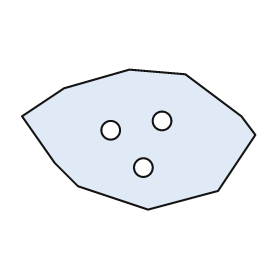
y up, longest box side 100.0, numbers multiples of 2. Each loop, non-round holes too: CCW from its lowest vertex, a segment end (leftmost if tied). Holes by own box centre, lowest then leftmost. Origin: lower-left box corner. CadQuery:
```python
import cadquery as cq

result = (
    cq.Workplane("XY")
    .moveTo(54.0, 0.0)
    .lineTo(84.0, 8.0)
    .lineTo(100.0, 32.0)
    .lineTo(94.0, 40.0)
    .lineTo(70.0, 58.0)
    .lineTo(46.0, 60.0)
    .lineTo(18.0, 52.0)
    .lineTo(0.0, 40.0)
    .lineTo(14.0, 20.0)
    .lineTo(24.0, 10.0)
    .close()
    .moveTo(52.0, 18.0)
    .circle(4.0)
    .moveTo(38.0, 34.0)
    .circle(4.0)
    .moveTo(60.0, 38.0)
    .circle(4.0)
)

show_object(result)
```